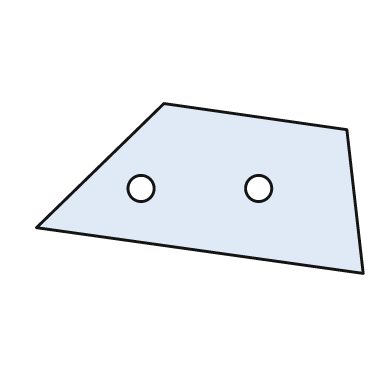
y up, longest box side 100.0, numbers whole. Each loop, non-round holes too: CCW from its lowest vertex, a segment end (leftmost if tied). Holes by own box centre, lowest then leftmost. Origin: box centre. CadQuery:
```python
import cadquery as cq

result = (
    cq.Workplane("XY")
    .moveTo(50.0, -26.0)
    .lineTo(45.0, 18.0)
    .lineTo(-11.0, 26.0)
    .lineTo(-50.0, -12.0)
    .close()
    .moveTo(-18.0, 0.0)
    .circle(4.0)
    .moveTo(18.0, 0.0)
    .circle(4.0)
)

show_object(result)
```